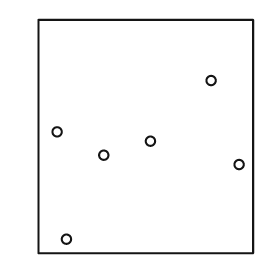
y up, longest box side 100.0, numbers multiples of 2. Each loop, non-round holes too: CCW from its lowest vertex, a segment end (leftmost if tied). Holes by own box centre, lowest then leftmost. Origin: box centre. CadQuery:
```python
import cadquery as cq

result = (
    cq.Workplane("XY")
    .moveTo(-46.0, -50.0)
    .lineTo(46.0, -50.0)
    .lineTo(46.0, 50.0)
    .lineTo(-46.0, 50.0)
    .close()
    .moveTo(-34.0, -44.0)
    .circle(2.0)
    .moveTo(40.0, -12.0)
    .circle(2.0)
    .moveTo(-18.0, -8.0)
    .circle(2.0)
    .moveTo(2.0, -2.0)
    .circle(2.0)
    .moveTo(-38.0, 2.0)
    .circle(2.0)
    .moveTo(28.0, 24.0)
    .circle(2.0)
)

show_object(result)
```